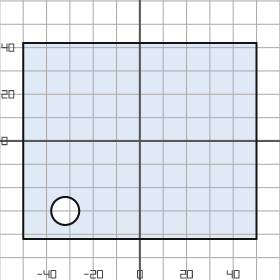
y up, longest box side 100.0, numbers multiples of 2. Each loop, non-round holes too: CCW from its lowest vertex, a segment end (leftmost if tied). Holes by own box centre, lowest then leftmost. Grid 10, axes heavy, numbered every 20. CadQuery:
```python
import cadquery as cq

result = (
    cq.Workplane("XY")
    .moveTo(-50.0, -42.0)
    .lineTo(50.0, -42.0)
    .lineTo(50.0, 42.0)
    .lineTo(-50.0, 42.0)
    .close()
    .moveTo(-32.0, -30.0)
    .circle(6.0)
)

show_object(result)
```